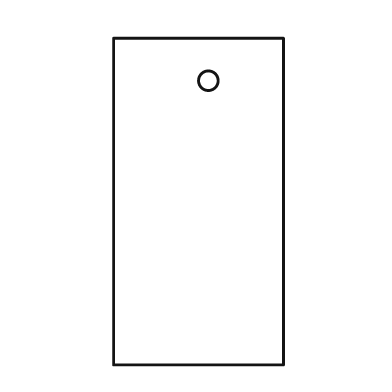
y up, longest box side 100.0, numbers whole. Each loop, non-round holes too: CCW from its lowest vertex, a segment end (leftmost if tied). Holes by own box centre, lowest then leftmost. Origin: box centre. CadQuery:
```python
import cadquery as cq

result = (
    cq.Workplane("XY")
    .moveTo(-26.0, -50.0)
    .lineTo(26.0, -50.0)
    .lineTo(26.0, 50.0)
    .lineTo(-26.0, 50.0)
    .close()
    .moveTo(3.0, 37.0)
    .circle(3.0)
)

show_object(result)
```